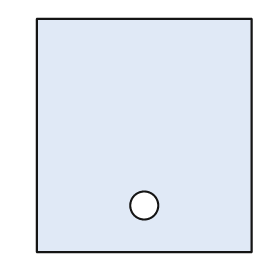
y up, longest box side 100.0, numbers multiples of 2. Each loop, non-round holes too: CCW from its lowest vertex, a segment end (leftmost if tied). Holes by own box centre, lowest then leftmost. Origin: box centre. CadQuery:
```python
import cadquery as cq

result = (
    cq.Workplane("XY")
    .moveTo(-46.0, -50.0)
    .lineTo(46.0, -50.0)
    .lineTo(46.0, 50.0)
    .lineTo(-46.0, 50.0)
    .close()
    .moveTo(0.0, -30.0)
    .circle(6.0)
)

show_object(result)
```